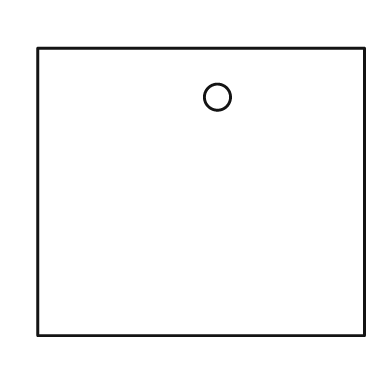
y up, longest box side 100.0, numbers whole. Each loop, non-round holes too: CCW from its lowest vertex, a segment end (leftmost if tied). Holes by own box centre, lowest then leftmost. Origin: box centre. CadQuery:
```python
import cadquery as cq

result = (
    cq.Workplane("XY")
    .moveTo(-50.0, -44.0)
    .lineTo(50.0, -44.0)
    .lineTo(50.0, 44.0)
    .lineTo(-50.0, 44.0)
    .close()
    .moveTo(5.0, 29.0)
    .circle(4.0)
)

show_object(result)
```